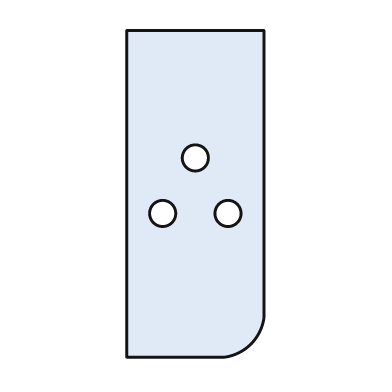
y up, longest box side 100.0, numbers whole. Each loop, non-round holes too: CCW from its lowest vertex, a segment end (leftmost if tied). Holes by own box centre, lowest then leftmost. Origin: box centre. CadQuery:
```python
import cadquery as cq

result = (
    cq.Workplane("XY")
    .moveTo(-21.0, -50.0)
    .lineTo(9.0, -50.0)
    .threePointArc((17.0, -46.0), (21.0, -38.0))
    .lineTo(21.0, 50.0)
    .lineTo(-21.0, 50.0)
    .close()
    .moveTo(-10.0, -6.0)
    .circle(4.0)
    .moveTo(10.0, -6.0)
    .circle(4.0)
    .moveTo(0.0, 11.0)
    .circle(4.0)
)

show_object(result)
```